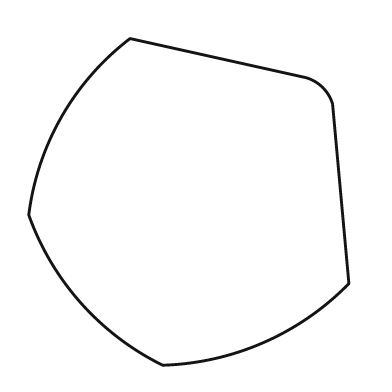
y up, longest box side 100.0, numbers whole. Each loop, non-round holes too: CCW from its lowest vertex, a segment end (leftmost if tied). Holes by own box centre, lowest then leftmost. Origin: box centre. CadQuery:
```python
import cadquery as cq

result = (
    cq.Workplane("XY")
    .moveTo(-8.0, -50.0)
    .threePointArc((23.0, -43.0), (49.0, -25.0))
    .lineTo(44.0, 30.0)
    .threePointArc((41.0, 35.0), (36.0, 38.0))
    .lineTo(-18.0, 50.0)
    .threePointArc((-39.0, 26.0), (-49.0, -4.0))
    .threePointArc((-33.0, -31.0), (-8.0, -50.0))
    .close()
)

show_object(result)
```